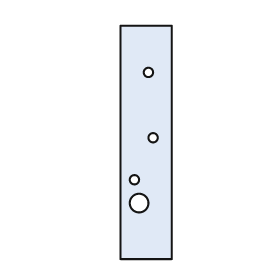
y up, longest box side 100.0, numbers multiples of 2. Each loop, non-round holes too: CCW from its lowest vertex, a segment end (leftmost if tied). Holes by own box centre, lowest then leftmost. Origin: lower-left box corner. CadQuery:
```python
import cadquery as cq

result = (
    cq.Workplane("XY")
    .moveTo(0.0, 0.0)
    .lineTo(22.0, 0.0)
    .lineTo(22.0, 100.0)
    .lineTo(0.0, 100.0)
    .close()
    .moveTo(8.0, 24.0)
    .circle(4.0)
    .moveTo(6.0, 34.0)
    .circle(2.0)
    .moveTo(14.0, 52.0)
    .circle(2.0)
    .moveTo(12.0, 80.0)
    .circle(2.0)
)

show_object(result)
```